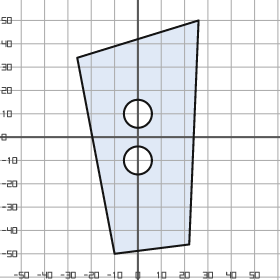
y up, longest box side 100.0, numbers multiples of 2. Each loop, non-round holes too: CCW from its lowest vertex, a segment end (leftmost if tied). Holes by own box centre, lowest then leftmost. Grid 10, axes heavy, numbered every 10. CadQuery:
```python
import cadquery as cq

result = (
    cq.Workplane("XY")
    .moveTo(-10.0, -50.0)
    .lineTo(22.0, -46.0)
    .lineTo(26.0, 50.0)
    .lineTo(-26.0, 34.0)
    .close()
    .moveTo(0.0, -10.0)
    .circle(6.0)
    .moveTo(0.0, 10.0)
    .circle(6.0)
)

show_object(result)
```